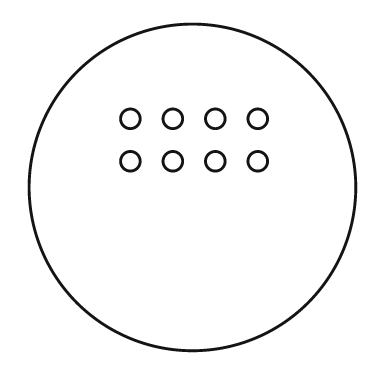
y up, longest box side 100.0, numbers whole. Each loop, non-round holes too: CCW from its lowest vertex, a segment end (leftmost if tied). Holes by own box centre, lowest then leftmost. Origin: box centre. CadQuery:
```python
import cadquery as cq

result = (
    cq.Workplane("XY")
    .moveTo(0.0, 0.0)
    .circle(50.0)
    .moveTo(-19.0, 8.0)
    .circle(3.0)
    .moveTo(-6.0, 8.0)
    .circle(3.0)
    .moveTo(7.0, 8.0)
    .circle(3.0)
    .moveTo(20.0, 8.0)
    .circle(3.0)
    .moveTo(-19.0, 21.0)
    .circle(3.0)
    .moveTo(-6.0, 21.0)
    .circle(3.0)
    .moveTo(7.0, 21.0)
    .circle(3.0)
    .moveTo(20.0, 21.0)
    .circle(3.0)
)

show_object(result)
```